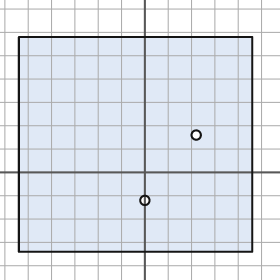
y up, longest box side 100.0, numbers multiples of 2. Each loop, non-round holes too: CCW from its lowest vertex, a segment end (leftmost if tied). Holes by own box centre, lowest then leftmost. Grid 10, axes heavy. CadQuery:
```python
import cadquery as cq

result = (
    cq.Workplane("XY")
    .moveTo(-54.0, -34.0)
    .lineTo(46.0, -34.0)
    .lineTo(46.0, 58.0)
    .lineTo(-54.0, 58.0)
    .close()
    .moveTo(0.0, -12.0)
    .circle(2.0)
    .moveTo(22.0, 16.0)
    .circle(2.0)
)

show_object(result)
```